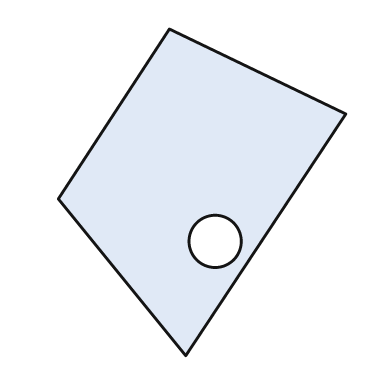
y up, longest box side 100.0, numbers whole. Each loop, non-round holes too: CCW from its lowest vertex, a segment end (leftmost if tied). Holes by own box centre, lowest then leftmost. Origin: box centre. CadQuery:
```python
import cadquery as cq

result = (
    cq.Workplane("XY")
    .moveTo(-5.0, -50.0)
    .lineTo(44.0, 24.0)
    .lineTo(-10.0, 50.0)
    .lineTo(-44.0, -2.0)
    .close()
    .moveTo(4.0, -15.0)
    .circle(8.0)
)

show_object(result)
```